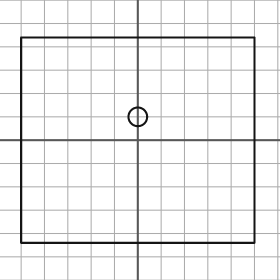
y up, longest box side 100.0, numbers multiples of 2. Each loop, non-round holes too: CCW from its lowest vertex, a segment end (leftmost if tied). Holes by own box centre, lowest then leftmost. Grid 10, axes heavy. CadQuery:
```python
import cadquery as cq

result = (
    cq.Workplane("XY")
    .moveTo(-50.0, -44.0)
    .lineTo(50.0, -44.0)
    .lineTo(50.0, 44.0)
    .lineTo(-50.0, 44.0)
    .close()
    .moveTo(0.0, 10.0)
    .circle(4.0)
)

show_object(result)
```